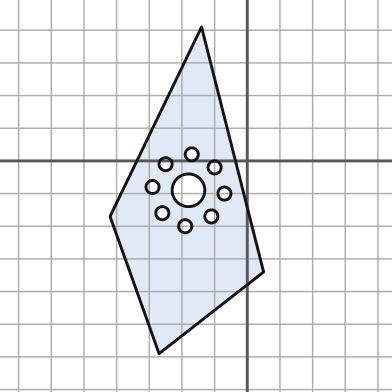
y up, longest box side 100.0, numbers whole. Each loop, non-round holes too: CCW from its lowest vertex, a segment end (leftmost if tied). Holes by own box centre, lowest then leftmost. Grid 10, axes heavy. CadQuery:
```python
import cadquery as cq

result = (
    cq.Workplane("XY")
    .moveTo(-27.0, -59.0)
    .lineTo(5.0, -34.0)
    .lineTo(-14.0, 41.0)
    .lineTo(-42.0, -17.0)
    .close()
    .moveTo(-19.0, -20.0)
    .circle(2.0)
    .moveTo(-11.0, -17.0)
    .circle(2.0)
    .moveTo(-26.0, -16.0)
    .circle(2.0)
    .moveTo(-7.0, -10.0)
    .circle(2.0)
    .moveTo(-18.0, -9.0)
    .circle(5.0)
    .moveTo(-29.0, -8.0)
    .circle(2.0)
    .moveTo(-10.0, -2.0)
    .circle(2.0)
    .moveTo(-25.0, -1.0)
    .circle(2.0)
    .moveTo(-17.0, 2.0)
    .circle(2.0)
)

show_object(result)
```